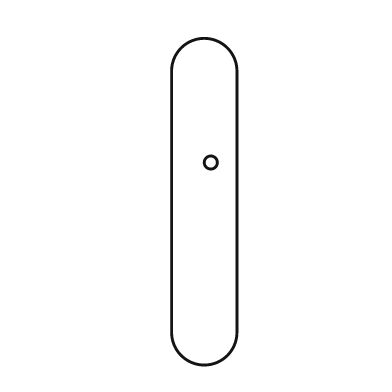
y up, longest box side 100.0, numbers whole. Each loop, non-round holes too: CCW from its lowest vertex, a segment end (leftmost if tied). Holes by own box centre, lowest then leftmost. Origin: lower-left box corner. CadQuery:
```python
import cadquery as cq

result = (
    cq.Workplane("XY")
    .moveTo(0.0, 10.0)
    .threePointArc((10.0, 0.0), (20.0, 10.0))
    .lineTo(20.0, 90.0)
    .threePointArc((10.0, 100.0), (0.0, 90.0))
    .close()
    .moveTo(12.0, 62.0)
    .circle(2.0)
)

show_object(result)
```